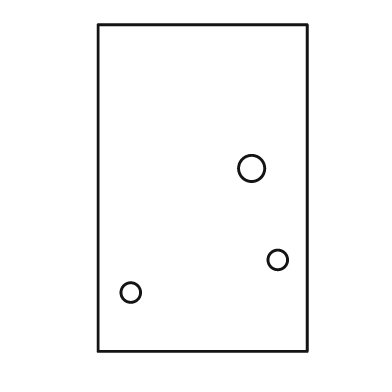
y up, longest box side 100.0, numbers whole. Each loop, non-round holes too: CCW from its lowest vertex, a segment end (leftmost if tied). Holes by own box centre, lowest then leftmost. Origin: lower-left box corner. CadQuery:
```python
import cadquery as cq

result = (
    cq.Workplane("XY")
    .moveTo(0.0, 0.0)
    .lineTo(64.0, 0.0)
    .lineTo(64.0, 100.0)
    .lineTo(0.0, 100.0)
    .close()
    .moveTo(10.0, 18.0)
    .circle(3.0)
    .moveTo(55.0, 28.0)
    .circle(3.0)
    .moveTo(47.0, 56.0)
    .circle(4.0)
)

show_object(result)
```